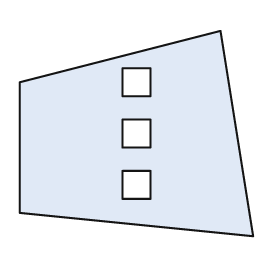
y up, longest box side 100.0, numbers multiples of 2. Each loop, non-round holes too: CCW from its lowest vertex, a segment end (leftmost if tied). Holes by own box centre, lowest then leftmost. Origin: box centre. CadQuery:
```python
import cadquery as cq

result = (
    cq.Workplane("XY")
    .moveTo(50.0, -44.0)
    .lineTo(36.0, 44.0)
    .lineTo(-50.0, 22.0)
    .lineTo(-50.0, -34.0)
    .close()
    .moveTo(-6.0, -28.0)
    .lineTo(6.0, -28.0)
    .lineTo(6.0, -16.0)
    .lineTo(-6.0, -16.0)
    .close()
    .moveTo(-6.0, -6.0)
    .lineTo(6.0, -6.0)
    .lineTo(6.0, 6.0)
    .lineTo(-6.0, 6.0)
    .close()
    .moveTo(-6.0, 16.0)
    .lineTo(6.0, 16.0)
    .lineTo(6.0, 28.0)
    .lineTo(-6.0, 28.0)
    .close()
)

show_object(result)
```